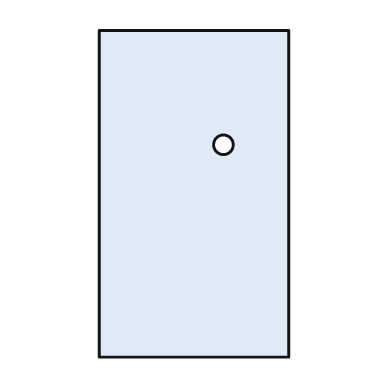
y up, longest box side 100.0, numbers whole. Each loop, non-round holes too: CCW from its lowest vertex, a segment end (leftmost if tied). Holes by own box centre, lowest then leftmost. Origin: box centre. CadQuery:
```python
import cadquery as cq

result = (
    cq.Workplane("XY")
    .moveTo(-29.0, -50.0)
    .lineTo(29.0, -50.0)
    .lineTo(29.0, 50.0)
    .lineTo(-29.0, 50.0)
    .close()
    .moveTo(9.0, 15.0)
    .circle(3.0)
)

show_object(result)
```